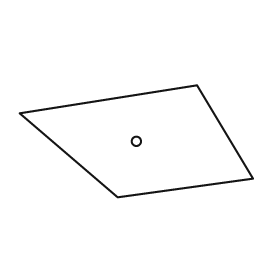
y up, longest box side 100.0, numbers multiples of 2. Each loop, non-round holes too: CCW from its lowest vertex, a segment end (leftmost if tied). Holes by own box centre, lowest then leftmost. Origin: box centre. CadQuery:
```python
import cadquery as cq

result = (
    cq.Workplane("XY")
    .moveTo(-8.0, -24.0)
    .lineTo(50.0, -16.0)
    .lineTo(26.0, 24.0)
    .lineTo(-50.0, 12.0)
    .close()
    .moveTo(0.0, 0.0)
    .circle(2.0)
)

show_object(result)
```